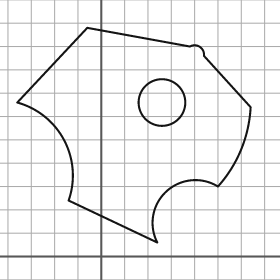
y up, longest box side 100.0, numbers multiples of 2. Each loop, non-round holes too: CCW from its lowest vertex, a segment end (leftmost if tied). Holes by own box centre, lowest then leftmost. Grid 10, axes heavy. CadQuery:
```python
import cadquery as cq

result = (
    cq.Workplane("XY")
    .moveTo(24.0, 6.0)
    .threePointArc((28.0, 28.0), (50.0, 30.0))
    .threePointArc((60.0, 46.0), (64.0, 64.0))
    .lineTo(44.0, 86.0)
    .threePointArc((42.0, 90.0), (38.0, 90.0))
    .lineTo(-6.0, 98.0)
    .lineTo(-36.0, 66.0)
    .threePointArc((-16.0, 50.0), (-14.0, 24.0))
    .close()
    .moveTo(26.0, 66.0)
    .circle(10.0)
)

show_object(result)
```